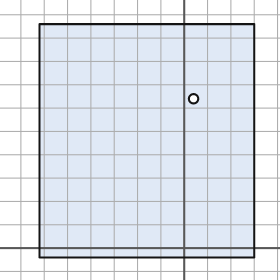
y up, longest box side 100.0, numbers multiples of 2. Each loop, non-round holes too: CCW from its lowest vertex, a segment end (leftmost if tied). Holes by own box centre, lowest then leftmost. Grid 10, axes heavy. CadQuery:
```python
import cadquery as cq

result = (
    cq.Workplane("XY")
    .moveTo(-62.0, -4.0)
    .lineTo(30.0, -4.0)
    .lineTo(30.0, 96.0)
    .lineTo(-62.0, 96.0)
    .close()
    .moveTo(4.0, 64.0)
    .circle(2.0)
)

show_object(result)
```